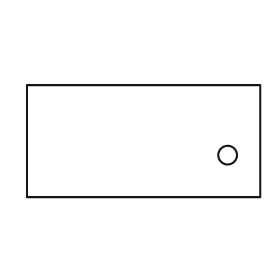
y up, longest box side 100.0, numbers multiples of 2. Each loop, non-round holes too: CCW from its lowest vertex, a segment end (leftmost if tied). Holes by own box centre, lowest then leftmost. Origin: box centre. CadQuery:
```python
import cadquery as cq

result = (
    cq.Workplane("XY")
    .moveTo(-50.0, -24.0)
    .lineTo(50.0, -24.0)
    .lineTo(50.0, 24.0)
    .lineTo(-50.0, 24.0)
    .close()
    .moveTo(36.0, -6.0)
    .circle(4.0)
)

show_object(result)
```